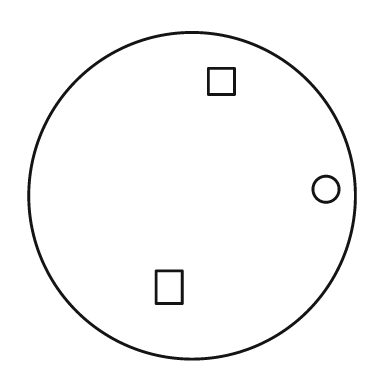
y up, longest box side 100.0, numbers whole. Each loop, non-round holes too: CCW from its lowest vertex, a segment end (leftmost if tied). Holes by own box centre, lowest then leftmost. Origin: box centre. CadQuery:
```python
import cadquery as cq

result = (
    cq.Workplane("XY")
    .moveTo(0.0, 0.0)
    .circle(50.0)
    .moveTo(-11.0, -33.0)
    .lineTo(-3.0, -33.0)
    .lineTo(-3.0, -23.0)
    .lineTo(-11.0, -23.0)
    .close()
    .moveTo(41.0, 2.0)
    .circle(4.0)
    .moveTo(5.0, 31.0)
    .lineTo(13.0, 31.0)
    .lineTo(13.0, 39.0)
    .lineTo(5.0, 39.0)
    .close()
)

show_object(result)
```